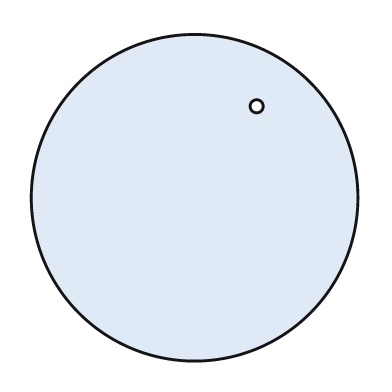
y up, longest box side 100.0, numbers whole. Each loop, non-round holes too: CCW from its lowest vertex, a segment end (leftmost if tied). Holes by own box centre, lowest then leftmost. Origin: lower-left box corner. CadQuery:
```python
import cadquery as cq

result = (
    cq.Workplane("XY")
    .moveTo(50.0, 50.0)
    .circle(50.0)
    .moveTo(69.0, 78.0)
    .circle(2.0)
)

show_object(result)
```